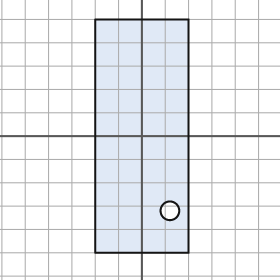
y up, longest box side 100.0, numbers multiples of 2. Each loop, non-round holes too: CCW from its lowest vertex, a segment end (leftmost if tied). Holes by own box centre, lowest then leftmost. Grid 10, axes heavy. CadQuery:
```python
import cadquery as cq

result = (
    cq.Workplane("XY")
    .moveTo(-20.0, -50.0)
    .lineTo(20.0, -50.0)
    .lineTo(20.0, 50.0)
    .lineTo(-20.0, 50.0)
    .close()
    .moveTo(12.0, -32.0)
    .circle(4.0)
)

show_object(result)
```